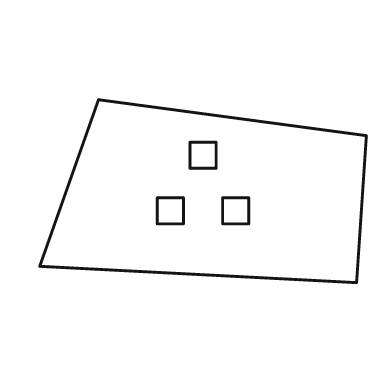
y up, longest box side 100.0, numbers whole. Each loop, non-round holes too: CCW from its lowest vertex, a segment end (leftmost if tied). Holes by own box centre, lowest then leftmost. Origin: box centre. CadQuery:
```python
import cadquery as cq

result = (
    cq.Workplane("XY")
    .moveTo(47.0, -28.0)
    .lineTo(50.0, 17.0)
    .lineTo(-32.0, 28.0)
    .lineTo(-50.0, -23.0)
    .close()
    .moveTo(-14.0, -10.0)
    .lineTo(-6.0, -10.0)
    .lineTo(-6.0, -2.0)
    .lineTo(-14.0, -2.0)
    .close()
    .moveTo(6.0, -10.0)
    .lineTo(14.0, -10.0)
    .lineTo(14.0, -2.0)
    .lineTo(6.0, -2.0)
    .close()
    .moveTo(-4.0, 7.0)
    .lineTo(4.0, 7.0)
    .lineTo(4.0, 15.0)
    .lineTo(-4.0, 15.0)
    .close()
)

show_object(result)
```